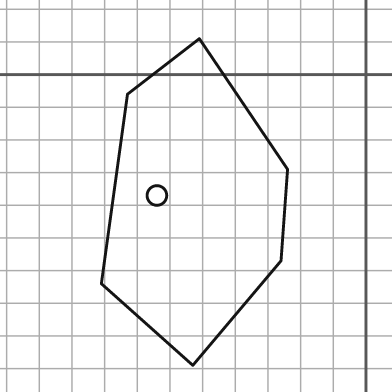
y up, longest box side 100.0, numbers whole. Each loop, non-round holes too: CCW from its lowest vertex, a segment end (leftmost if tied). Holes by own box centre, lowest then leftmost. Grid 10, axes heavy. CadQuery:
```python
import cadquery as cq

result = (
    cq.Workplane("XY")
    .moveTo(-53.0, -89.0)
    .lineTo(-26.0, -57.0)
    .lineTo(-24.0, -29.0)
    .lineTo(-51.0, 11.0)
    .lineTo(-73.0, -6.0)
    .lineTo(-81.0, -64.0)
    .close()
    .moveTo(-64.0, -37.0)
    .circle(3.0)
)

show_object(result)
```